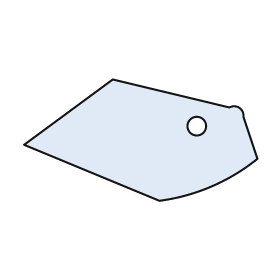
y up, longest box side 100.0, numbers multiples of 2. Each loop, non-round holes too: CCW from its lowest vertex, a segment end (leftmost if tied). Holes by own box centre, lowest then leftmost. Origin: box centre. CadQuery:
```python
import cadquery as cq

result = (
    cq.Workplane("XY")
    .moveTo(8.0, -26.0)
    .threePointArc((30.0, -20.0), (50.0, -8.0))
    .lineTo(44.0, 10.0)
    .threePointArc((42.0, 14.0), (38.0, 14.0))
    .lineTo(-12.0, 26.0)
    .lineTo(-50.0, -2.0)
    .close()
    .moveTo(24.0, 6.0)
    .circle(4.0)
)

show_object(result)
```